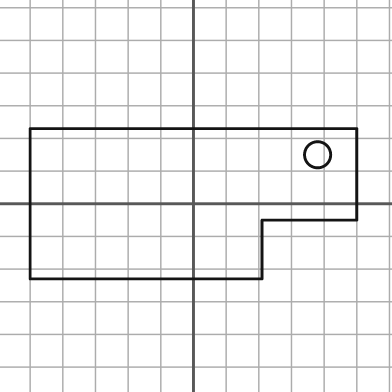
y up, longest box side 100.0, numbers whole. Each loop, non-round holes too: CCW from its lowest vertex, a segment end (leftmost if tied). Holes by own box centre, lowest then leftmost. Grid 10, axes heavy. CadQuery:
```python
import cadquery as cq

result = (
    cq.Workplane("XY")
    .moveTo(-50.0, -23.0)
    .lineTo(21.0, -23.0)
    .lineTo(21.0, -5.0)
    .lineTo(50.0, -5.0)
    .lineTo(50.0, 23.0)
    .lineTo(-50.0, 23.0)
    .close()
    .moveTo(38.0, 15.0)
    .circle(4.0)
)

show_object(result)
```